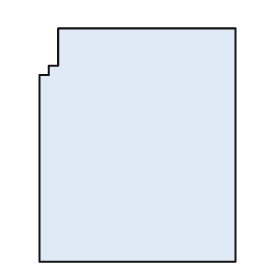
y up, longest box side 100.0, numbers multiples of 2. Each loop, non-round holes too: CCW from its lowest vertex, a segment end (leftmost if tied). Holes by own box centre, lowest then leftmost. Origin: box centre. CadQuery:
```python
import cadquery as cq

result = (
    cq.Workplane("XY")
    .moveTo(-42.0, -50.0)
    .lineTo(42.0, -50.0)
    .lineTo(42.0, 50.0)
    .lineTo(-34.0, 50.0)
    .lineTo(-34.0, 34.0)
    .lineTo(-38.0, 34.0)
    .lineTo(-38.0, 30.0)
    .lineTo(-42.0, 30.0)
    .close()
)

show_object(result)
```